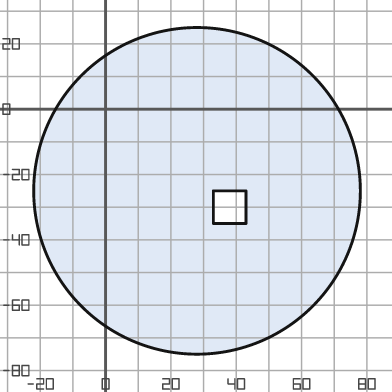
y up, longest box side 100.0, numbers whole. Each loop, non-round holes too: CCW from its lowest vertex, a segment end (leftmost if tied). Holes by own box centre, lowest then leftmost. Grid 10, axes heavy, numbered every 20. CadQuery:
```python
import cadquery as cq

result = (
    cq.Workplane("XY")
    .moveTo(28.0, -25.0)
    .circle(50.0)
    .moveTo(33.0, -35.0)
    .lineTo(43.0, -35.0)
    .lineTo(43.0, -25.0)
    .lineTo(33.0, -25.0)
    .close()
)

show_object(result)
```